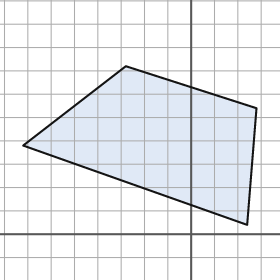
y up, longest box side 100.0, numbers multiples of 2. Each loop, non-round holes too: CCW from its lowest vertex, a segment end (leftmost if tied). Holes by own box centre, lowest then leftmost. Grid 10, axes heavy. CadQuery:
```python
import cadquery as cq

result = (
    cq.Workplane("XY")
    .moveTo(24.0, 4.0)
    .lineTo(28.0, 54.0)
    .lineTo(-28.0, 72.0)
    .lineTo(-72.0, 38.0)
    .close()
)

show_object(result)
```